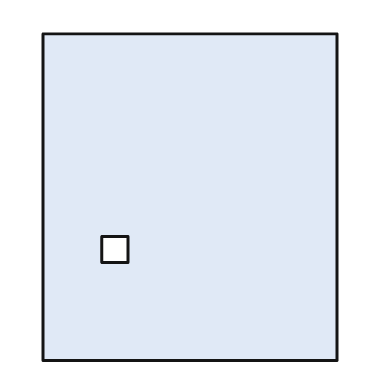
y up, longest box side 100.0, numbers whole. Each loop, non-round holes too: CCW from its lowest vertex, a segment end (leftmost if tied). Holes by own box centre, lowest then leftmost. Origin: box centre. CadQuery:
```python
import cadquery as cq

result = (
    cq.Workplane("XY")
    .moveTo(-45.0, -50.0)
    .lineTo(45.0, -50.0)
    .lineTo(45.0, 50.0)
    .lineTo(-45.0, 50.0)
    .close()
    .moveTo(-27.0, -20.0)
    .lineTo(-19.0, -20.0)
    .lineTo(-19.0, -12.0)
    .lineTo(-27.0, -12.0)
    .close()
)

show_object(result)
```